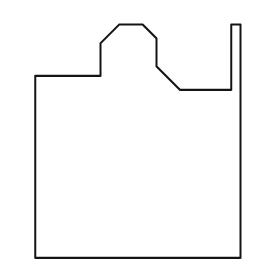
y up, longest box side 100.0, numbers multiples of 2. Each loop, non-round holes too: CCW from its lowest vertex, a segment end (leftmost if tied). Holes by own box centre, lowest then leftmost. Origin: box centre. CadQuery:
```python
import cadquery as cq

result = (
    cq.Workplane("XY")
    .moveTo(-44.0, -50.0)
    .lineTo(44.0, -50.0)
    .lineTo(44.0, 50.0)
    .lineTo(40.0, 50.0)
    .lineTo(40.0, 22.0)
    .lineTo(18.0, 22.0)
    .lineTo(8.0, 32.0)
    .lineTo(8.0, 44.0)
    .lineTo(2.0, 50.0)
    .lineTo(-8.0, 50.0)
    .lineTo(-16.0, 42.0)
    .lineTo(-16.0, 28.0)
    .lineTo(-44.0, 28.0)
    .close()
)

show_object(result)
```